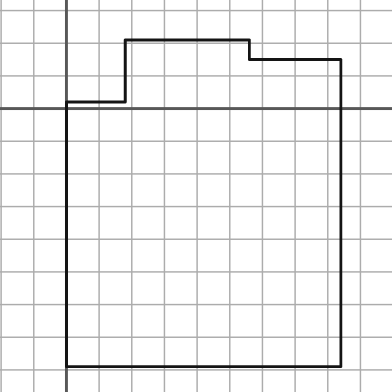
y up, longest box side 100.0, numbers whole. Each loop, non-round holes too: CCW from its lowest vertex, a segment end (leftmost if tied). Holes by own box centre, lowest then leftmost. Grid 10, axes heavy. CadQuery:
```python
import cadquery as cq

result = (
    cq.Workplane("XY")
    .moveTo(0.0, -79.0)
    .lineTo(84.0, -79.0)
    .lineTo(84.0, 15.0)
    .lineTo(56.0, 15.0)
    .lineTo(56.0, 21.0)
    .lineTo(18.0, 21.0)
    .lineTo(18.0, 2.0)
    .lineTo(0.0, 2.0)
    .close()
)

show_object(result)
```